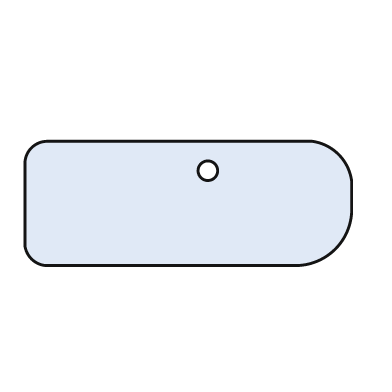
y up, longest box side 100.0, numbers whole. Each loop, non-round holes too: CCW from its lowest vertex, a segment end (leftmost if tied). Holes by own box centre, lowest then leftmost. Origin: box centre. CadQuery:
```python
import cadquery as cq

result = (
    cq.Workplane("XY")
    .moveTo(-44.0, -19.0)
    .lineTo(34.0, -19.0)
    .threePointArc((45.0, -14.0), (50.0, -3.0))
    .lineTo(50.0, 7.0)
    .threePointArc((46.0, 15.0), (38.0, 19.0))
    .lineTo(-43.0, 19.0)
    .threePointArc((-48.0, 17.0), (-50.0, 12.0))
    .lineTo(-50.0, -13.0)
    .threePointArc((-48.0, -17.0), (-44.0, -19.0))
    .close()
    .moveTo(6.0, 10.0)
    .circle(3.0)
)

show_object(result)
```